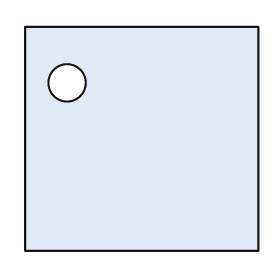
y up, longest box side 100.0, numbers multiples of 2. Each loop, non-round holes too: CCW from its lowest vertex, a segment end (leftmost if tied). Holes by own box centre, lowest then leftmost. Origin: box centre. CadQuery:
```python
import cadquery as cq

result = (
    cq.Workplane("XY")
    .moveTo(-50.0, -48.0)
    .lineTo(50.0, -48.0)
    .lineTo(50.0, 48.0)
    .lineTo(-50.0, 48.0)
    .close()
    .moveTo(-32.0, 24.0)
    .circle(8.0)
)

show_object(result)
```